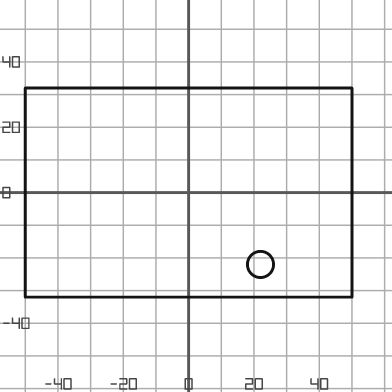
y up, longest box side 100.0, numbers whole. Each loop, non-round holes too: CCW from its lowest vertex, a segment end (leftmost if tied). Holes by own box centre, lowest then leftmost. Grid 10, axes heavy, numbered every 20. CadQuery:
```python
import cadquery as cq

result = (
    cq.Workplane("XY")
    .moveTo(-50.0, -32.0)
    .lineTo(50.0, -32.0)
    .lineTo(50.0, 32.0)
    .lineTo(-50.0, 32.0)
    .close()
    .moveTo(22.0, -22.0)
    .circle(4.0)
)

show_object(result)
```